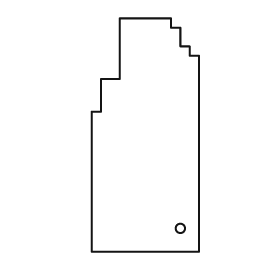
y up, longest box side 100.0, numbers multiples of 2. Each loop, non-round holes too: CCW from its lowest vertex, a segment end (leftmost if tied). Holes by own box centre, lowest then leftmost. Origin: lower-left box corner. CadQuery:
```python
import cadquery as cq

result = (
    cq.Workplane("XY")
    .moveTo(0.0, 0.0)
    .lineTo(46.0, 0.0)
    .lineTo(46.0, 84.0)
    .lineTo(42.0, 84.0)
    .lineTo(42.0, 88.0)
    .lineTo(38.0, 88.0)
    .lineTo(38.0, 96.0)
    .lineTo(34.0, 96.0)
    .lineTo(34.0, 100.0)
    .lineTo(12.0, 100.0)
    .lineTo(12.0, 74.0)
    .lineTo(4.0, 74.0)
    .lineTo(4.0, 60.0)
    .lineTo(0.0, 60.0)
    .close()
    .moveTo(38.0, 10.0)
    .circle(2.0)
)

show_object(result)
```